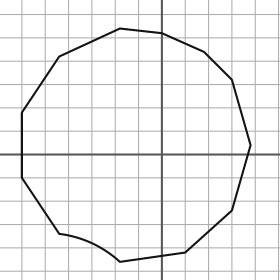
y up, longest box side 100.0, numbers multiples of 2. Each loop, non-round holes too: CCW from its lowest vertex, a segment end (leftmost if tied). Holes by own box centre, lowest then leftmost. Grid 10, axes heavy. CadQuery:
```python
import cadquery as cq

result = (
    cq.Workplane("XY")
    .moveTo(-18.0, -46.0)
    .lineTo(10.0, -42.0)
    .lineTo(30.0, -24.0)
    .lineTo(38.0, 4.0)
    .lineTo(30.0, 32.0)
    .lineTo(18.0, 44.0)
    .lineTo(0.0, 52.0)
    .lineTo(-18.0, 54.0)
    .lineTo(-44.0, 42.0)
    .lineTo(-60.0, 18.0)
    .lineTo(-60.0, -10.0)
    .lineTo(-44.0, -34.0)
    .threePointArc((-30.0, -38.0), (-18.0, -46.0))
    .close()
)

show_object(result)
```